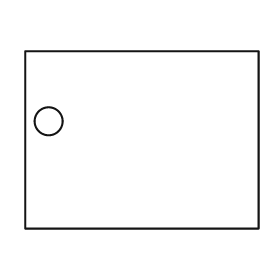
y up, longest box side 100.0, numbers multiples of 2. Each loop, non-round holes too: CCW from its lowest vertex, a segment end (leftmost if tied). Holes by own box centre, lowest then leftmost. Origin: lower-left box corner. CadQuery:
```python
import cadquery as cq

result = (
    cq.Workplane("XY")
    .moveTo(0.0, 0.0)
    .lineTo(100.0, 0.0)
    .lineTo(100.0, 76.0)
    .lineTo(0.0, 76.0)
    .close()
    .moveTo(10.0, 46.0)
    .circle(6.0)
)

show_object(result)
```